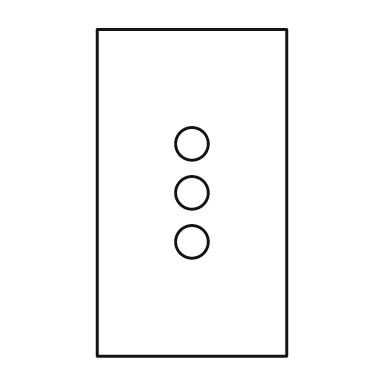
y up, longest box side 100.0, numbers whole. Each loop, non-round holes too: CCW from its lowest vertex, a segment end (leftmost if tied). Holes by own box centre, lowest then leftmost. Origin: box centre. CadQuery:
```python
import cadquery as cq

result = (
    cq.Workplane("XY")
    .moveTo(-29.0, -50.0)
    .lineTo(29.0, -50.0)
    .lineTo(29.0, 50.0)
    .lineTo(-29.0, 50.0)
    .close()
    .moveTo(0.0, -15.0)
    .circle(5.0)
    .moveTo(0.0, 0.0)
    .circle(5.0)
    .moveTo(0.0, 15.0)
    .circle(5.0)
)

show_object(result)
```